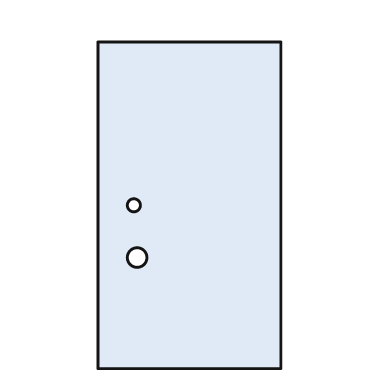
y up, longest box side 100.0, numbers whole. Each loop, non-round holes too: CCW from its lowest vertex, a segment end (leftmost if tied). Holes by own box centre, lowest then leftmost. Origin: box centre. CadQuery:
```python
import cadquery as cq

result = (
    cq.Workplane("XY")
    .moveTo(-28.0, -50.0)
    .lineTo(28.0, -50.0)
    .lineTo(28.0, 50.0)
    .lineTo(-28.0, 50.0)
    .close()
    .moveTo(-16.0, -16.0)
    .circle(3.0)
    .moveTo(-17.0, 0.0)
    .circle(2.0)
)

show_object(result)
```